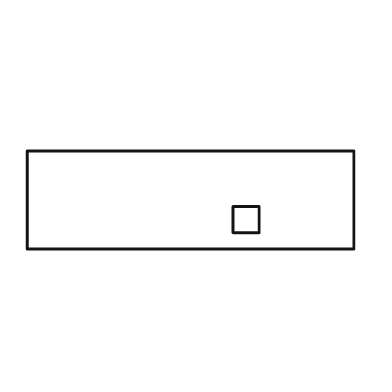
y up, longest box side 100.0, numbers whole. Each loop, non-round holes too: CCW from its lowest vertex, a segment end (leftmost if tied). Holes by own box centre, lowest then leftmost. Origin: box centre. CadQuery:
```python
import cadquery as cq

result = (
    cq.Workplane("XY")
    .moveTo(-50.0, -15.0)
    .lineTo(50.0, -15.0)
    .lineTo(50.0, 15.0)
    .lineTo(-50.0, 15.0)
    .close()
    .moveTo(13.0, -10.0)
    .lineTo(21.0, -10.0)
    .lineTo(21.0, -2.0)
    .lineTo(13.0, -2.0)
    .close()
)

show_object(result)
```